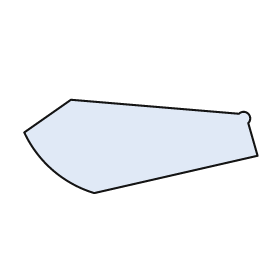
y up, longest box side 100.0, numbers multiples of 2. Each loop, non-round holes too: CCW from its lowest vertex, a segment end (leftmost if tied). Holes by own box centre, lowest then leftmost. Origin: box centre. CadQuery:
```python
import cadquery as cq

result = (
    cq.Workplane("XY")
    .moveTo(-20.0, -20.0)
    .lineTo(50.0, -4.0)
    .lineTo(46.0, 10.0)
    .threePointArc((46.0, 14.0), (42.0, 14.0))
    .lineTo(-30.0, 20.0)
    .lineTo(-50.0, 6.0)
    .threePointArc((-38.0, -10.0), (-20.0, -20.0))
    .close()
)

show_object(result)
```